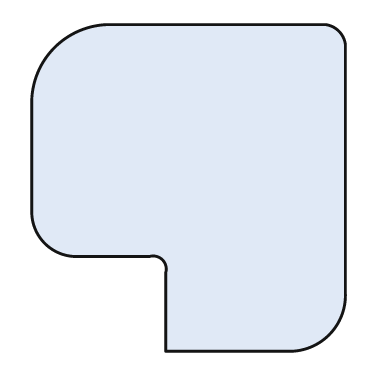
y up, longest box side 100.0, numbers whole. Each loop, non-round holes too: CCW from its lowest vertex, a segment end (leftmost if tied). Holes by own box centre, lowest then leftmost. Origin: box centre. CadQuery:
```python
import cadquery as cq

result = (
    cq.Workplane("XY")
    .moveTo(-7.0, -50.0)
    .lineTo(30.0, -50.0)
    .threePointArc((43.0, -45.0), (48.0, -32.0))
    .lineTo(48.0, 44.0)
    .threePointArc((46.0, 48.0), (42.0, 50.0))
    .lineTo(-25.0, 50.0)
    .threePointArc((-41.0, 43.0), (-48.0, 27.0))
    .lineTo(-48.0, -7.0)
    .threePointArc((-44.0, -17.0), (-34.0, -21.0))
    .lineTo(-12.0, -21.0)
    .threePointArc((-8.0, -22.0), (-7.0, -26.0))
    .close()
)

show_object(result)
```